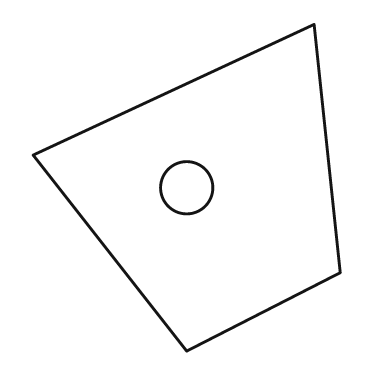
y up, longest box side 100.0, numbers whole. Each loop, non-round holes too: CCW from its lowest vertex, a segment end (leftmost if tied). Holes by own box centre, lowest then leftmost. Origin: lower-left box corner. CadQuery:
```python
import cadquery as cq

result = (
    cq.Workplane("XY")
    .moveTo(47.0, 0.0)
    .lineTo(94.0, 24.0)
    .lineTo(86.0, 100.0)
    .lineTo(0.0, 60.0)
    .close()
    .moveTo(47.0, 50.0)
    .circle(8.0)
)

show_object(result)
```